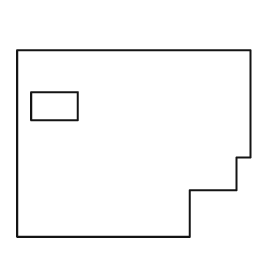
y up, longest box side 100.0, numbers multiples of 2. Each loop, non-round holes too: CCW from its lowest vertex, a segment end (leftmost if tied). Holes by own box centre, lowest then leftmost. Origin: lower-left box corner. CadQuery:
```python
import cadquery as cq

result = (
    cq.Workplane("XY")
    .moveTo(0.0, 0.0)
    .lineTo(74.0, 0.0)
    .lineTo(74.0, 20.0)
    .lineTo(94.0, 20.0)
    .lineTo(94.0, 34.0)
    .lineTo(100.0, 34.0)
    .lineTo(100.0, 80.0)
    .lineTo(0.0, 80.0)
    .close()
    .moveTo(6.0, 50.0)
    .lineTo(26.0, 50.0)
    .lineTo(26.0, 62.0)
    .lineTo(6.0, 62.0)
    .close()
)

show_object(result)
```